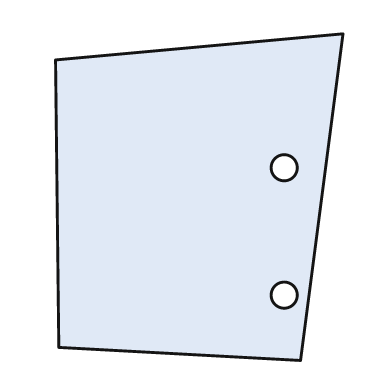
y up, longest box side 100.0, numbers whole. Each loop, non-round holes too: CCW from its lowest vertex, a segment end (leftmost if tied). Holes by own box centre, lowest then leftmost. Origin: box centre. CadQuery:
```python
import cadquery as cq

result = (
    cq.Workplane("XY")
    .moveTo(31.0, -50.0)
    .lineTo(44.0, 50.0)
    .lineTo(-44.0, 42.0)
    .lineTo(-43.0, -46.0)
    .close()
    .moveTo(26.0, -30.0)
    .circle(4.0)
    .moveTo(26.0, 9.0)
    .circle(4.0)
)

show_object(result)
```